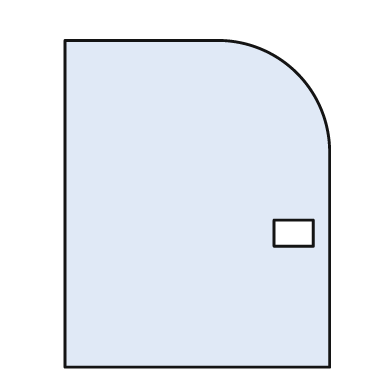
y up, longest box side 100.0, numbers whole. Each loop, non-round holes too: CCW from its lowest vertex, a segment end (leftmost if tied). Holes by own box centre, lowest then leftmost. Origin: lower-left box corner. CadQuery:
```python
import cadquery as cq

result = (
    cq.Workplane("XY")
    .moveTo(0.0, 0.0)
    .lineTo(81.0, 0.0)
    .lineTo(81.0, 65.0)
    .threePointArc((71.0, 90.0), (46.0, 100.0))
    .lineTo(0.0, 100.0)
    .close()
    .moveTo(64.0, 37.0)
    .lineTo(76.0, 37.0)
    .lineTo(76.0, 45.0)
    .lineTo(64.0, 45.0)
    .close()
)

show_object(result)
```